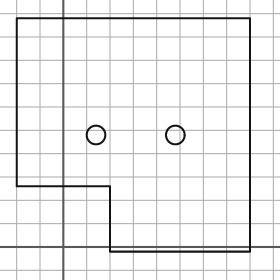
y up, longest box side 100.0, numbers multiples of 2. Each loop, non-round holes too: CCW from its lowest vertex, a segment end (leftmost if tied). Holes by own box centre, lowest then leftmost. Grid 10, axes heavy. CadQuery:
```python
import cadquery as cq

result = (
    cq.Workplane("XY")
    .moveTo(20.0, -2.0)
    .lineTo(80.0, -2.0)
    .lineTo(80.0, 98.0)
    .lineTo(-20.0, 98.0)
    .lineTo(-20.0, 26.0)
    .lineTo(20.0, 26.0)
    .close()
    .moveTo(14.0, 48.0)
    .circle(4.0)
    .moveTo(48.0, 48.0)
    .circle(4.0)
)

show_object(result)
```